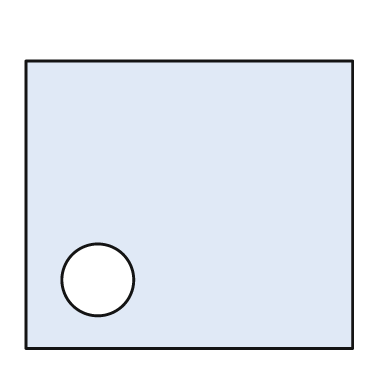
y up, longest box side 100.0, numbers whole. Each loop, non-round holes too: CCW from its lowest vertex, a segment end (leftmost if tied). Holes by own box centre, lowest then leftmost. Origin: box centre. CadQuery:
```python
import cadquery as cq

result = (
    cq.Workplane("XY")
    .moveTo(-50.0, -44.0)
    .lineTo(50.0, -44.0)
    .lineTo(50.0, 44.0)
    .lineTo(-50.0, 44.0)
    .close()
    .moveTo(-28.0, -23.0)
    .circle(11.0)
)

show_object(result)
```